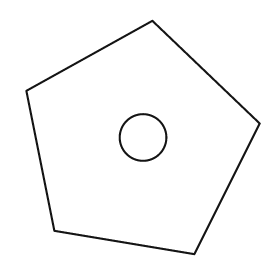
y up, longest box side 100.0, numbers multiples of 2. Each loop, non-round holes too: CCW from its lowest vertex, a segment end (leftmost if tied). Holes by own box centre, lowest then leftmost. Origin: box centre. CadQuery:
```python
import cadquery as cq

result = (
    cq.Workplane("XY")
    .moveTo(22.0, -50.0)
    .lineTo(50.0, 6.0)
    .lineTo(4.0, 50.0)
    .lineTo(-50.0, 20.0)
    .lineTo(-38.0, -40.0)
    .close()
    .moveTo(0.0, 0.0)
    .circle(10.0)
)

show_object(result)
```